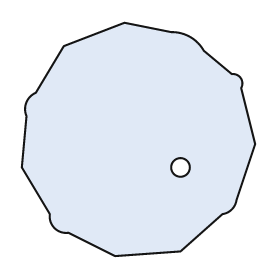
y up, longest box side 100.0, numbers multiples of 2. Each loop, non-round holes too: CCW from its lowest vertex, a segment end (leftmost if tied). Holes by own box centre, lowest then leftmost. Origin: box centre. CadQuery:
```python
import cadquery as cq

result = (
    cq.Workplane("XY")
    .moveTo(-10.0, -50.0)
    .lineTo(18.0, -48.0)
    .lineTo(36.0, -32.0)
    .threePointArc((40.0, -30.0), (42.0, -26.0))
    .lineTo(50.0, -2.0)
    .lineTo(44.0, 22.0)
    .threePointArc((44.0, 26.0), (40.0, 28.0))
    .lineTo(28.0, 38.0)
    .threePointArc((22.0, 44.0), (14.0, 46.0))
    .lineTo(-6.0, 50.0)
    .lineTo(-32.0, 40.0)
    .lineTo(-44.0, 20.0)
    .threePointArc((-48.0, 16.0), (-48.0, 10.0))
    .lineTo(-50.0, -12.0)
    .lineTo(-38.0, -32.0)
    .threePointArc((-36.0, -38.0), (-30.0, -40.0))
    .close()
    .moveTo(18.0, -12.0)
    .circle(4.0)
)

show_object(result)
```